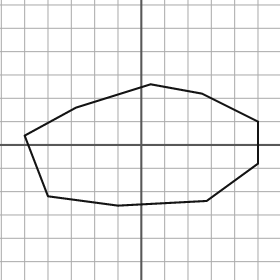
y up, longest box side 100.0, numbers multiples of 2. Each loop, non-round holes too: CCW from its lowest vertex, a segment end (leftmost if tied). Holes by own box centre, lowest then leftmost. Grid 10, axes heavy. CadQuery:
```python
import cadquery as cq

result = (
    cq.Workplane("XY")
    .moveTo(-10.0, -26.0)
    .lineTo(28.0, -24.0)
    .lineTo(50.0, -8.0)
    .lineTo(50.0, 10.0)
    .lineTo(26.0, 22.0)
    .lineTo(4.0, 26.0)
    .lineTo(-28.0, 16.0)
    .lineTo(-50.0, 4.0)
    .lineTo(-40.0, -22.0)
    .close()
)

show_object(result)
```